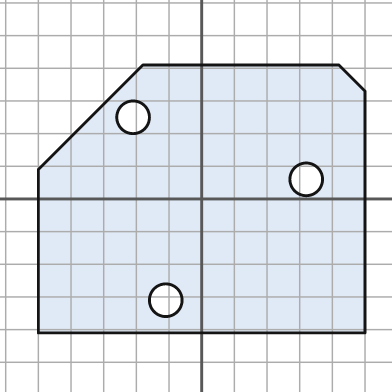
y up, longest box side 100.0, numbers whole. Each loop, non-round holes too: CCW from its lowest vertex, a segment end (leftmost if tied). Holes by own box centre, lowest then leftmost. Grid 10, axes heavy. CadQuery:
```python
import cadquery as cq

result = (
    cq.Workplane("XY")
    .moveTo(-50.0, -41.0)
    .lineTo(50.0, -41.0)
    .lineTo(50.0, 33.0)
    .lineTo(42.0, 41.0)
    .lineTo(-18.0, 41.0)
    .lineTo(-50.0, 9.0)
    .close()
    .moveTo(-11.0, -31.0)
    .circle(5.0)
    .moveTo(32.0, 6.0)
    .circle(5.0)
    .moveTo(-21.0, 25.0)
    .circle(5.0)
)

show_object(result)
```